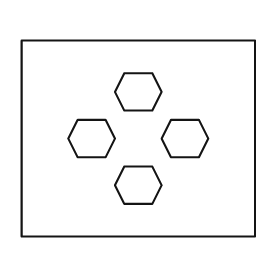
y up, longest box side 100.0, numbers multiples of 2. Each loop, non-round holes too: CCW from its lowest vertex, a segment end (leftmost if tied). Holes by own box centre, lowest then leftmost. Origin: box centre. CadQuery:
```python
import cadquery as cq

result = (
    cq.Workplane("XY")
    .moveTo(-50.0, -42.0)
    .lineTo(50.0, -42.0)
    .lineTo(50.0, 42.0)
    .lineTo(-50.0, 42.0)
    .close()
    .moveTo(-6.0, -28.0)
    .lineTo(6.0, -28.0)
    .lineTo(10.0, -20.0)
    .lineTo(6.0, -12.0)
    .lineTo(-6.0, -12.0)
    .lineTo(-10.0, -20.0)
    .close()
    .moveTo(-26.0, -8.0)
    .lineTo(-14.0, -8.0)
    .lineTo(-10.0, 0.0)
    .lineTo(-14.0, 8.0)
    .lineTo(-26.0, 8.0)
    .lineTo(-30.0, 0.0)
    .close()
    .moveTo(14.0, -8.0)
    .lineTo(26.0, -8.0)
    .lineTo(30.0, 0.0)
    .lineTo(26.0, 8.0)
    .lineTo(14.0, 8.0)
    .lineTo(10.0, 0.0)
    .close()
    .moveTo(-6.0, 12.0)
    .lineTo(6.0, 12.0)
    .lineTo(10.0, 20.0)
    .lineTo(6.0, 28.0)
    .lineTo(-6.0, 28.0)
    .lineTo(-10.0, 20.0)
    .close()
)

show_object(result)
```